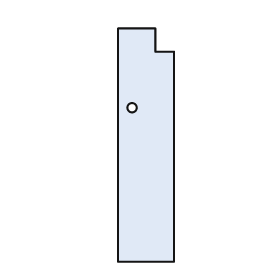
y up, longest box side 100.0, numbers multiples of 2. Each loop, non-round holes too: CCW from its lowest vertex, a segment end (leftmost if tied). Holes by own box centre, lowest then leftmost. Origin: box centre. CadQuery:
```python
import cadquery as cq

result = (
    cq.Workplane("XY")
    .moveTo(-12.0, -50.0)
    .lineTo(12.0, -50.0)
    .lineTo(12.0, 40.0)
    .lineTo(4.0, 40.0)
    .lineTo(4.0, 50.0)
    .lineTo(-12.0, 50.0)
    .close()
    .moveTo(-6.0, 16.0)
    .circle(2.0)
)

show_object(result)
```